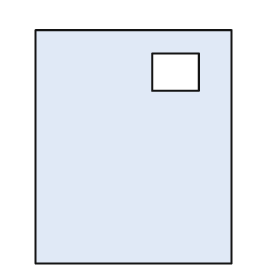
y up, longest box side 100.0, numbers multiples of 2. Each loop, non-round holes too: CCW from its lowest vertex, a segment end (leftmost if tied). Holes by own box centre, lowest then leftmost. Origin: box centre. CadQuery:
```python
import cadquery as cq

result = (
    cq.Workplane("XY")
    .moveTo(-42.0, -50.0)
    .lineTo(42.0, -50.0)
    .lineTo(42.0, 50.0)
    .lineTo(-42.0, 50.0)
    .close()
    .moveTo(8.0, 24.0)
    .lineTo(28.0, 24.0)
    .lineTo(28.0, 40.0)
    .lineTo(8.0, 40.0)
    .close()
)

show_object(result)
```